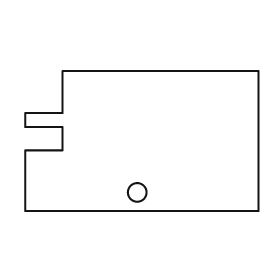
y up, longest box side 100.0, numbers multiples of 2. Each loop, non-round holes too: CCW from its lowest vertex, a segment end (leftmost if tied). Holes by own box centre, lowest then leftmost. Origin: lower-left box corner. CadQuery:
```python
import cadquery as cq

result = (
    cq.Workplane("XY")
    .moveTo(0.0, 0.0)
    .lineTo(100.0, 0.0)
    .lineTo(100.0, 60.0)
    .lineTo(16.0, 60.0)
    .lineTo(16.0, 42.0)
    .lineTo(0.0, 42.0)
    .lineTo(0.0, 36.0)
    .lineTo(16.0, 36.0)
    .lineTo(16.0, 26.0)
    .lineTo(0.0, 26.0)
    .close()
    .moveTo(48.0, 8.0)
    .circle(4.0)
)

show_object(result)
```